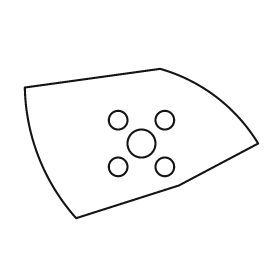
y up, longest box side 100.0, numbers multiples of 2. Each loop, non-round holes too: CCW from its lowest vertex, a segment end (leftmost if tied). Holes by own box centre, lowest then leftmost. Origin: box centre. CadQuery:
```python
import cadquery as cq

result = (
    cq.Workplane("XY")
    .moveTo(-28.0, -32.0)
    .lineTo(16.0, -18.0)
    .lineTo(50.0, 0.0)
    .threePointArc((32.0, 20.0), (8.0, 32.0))
    .lineTo(-50.0, 24.0)
    .threePointArc((-44.0, -6.0), (-28.0, -32.0))
    .close()
    .moveTo(-10.0, -10.0)
    .circle(4.0)
    .moveTo(10.0, -10.0)
    .circle(4.0)
    .moveTo(0.0, 0.0)
    .circle(6.0)
    .moveTo(-10.0, 10.0)
    .circle(4.0)
    .moveTo(10.0, 10.0)
    .circle(4.0)
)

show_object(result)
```